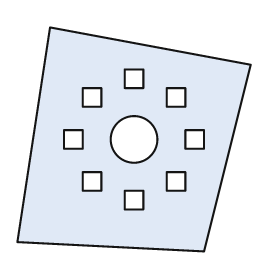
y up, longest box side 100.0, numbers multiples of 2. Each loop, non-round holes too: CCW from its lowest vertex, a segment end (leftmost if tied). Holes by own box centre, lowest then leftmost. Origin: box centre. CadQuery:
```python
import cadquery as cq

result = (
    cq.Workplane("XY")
    .moveTo(30.0, -48.0)
    .lineTo(50.0, 32.0)
    .lineTo(-36.0, 48.0)
    .lineTo(-50.0, -44.0)
    .close()
    .moveTo(-4.0, -30.0)
    .lineTo(4.0, -30.0)
    .lineTo(4.0, -22.0)
    .lineTo(-4.0, -22.0)
    .close()
    .moveTo(-22.0, -22.0)
    .lineTo(-14.0, -22.0)
    .lineTo(-14.0, -14.0)
    .lineTo(-22.0, -14.0)
    .close()
    .moveTo(14.0, -22.0)
    .lineTo(22.0, -22.0)
    .lineTo(22.0, -14.0)
    .lineTo(14.0, -14.0)
    .close()
    .moveTo(-30.0, -4.0)
    .lineTo(-22.0, -4.0)
    .lineTo(-22.0, 4.0)
    .lineTo(-30.0, 4.0)
    .close()
    .moveTo(0.0, 0.0)
    .circle(10.0)
    .moveTo(22.0, -4.0)
    .lineTo(30.0, -4.0)
    .lineTo(30.0, 4.0)
    .lineTo(22.0, 4.0)
    .close()
    .moveTo(-22.0, 14.0)
    .lineTo(-14.0, 14.0)
    .lineTo(-14.0, 22.0)
    .lineTo(-22.0, 22.0)
    .close()
    .moveTo(14.0, 14.0)
    .lineTo(22.0, 14.0)
    .lineTo(22.0, 22.0)
    .lineTo(14.0, 22.0)
    .close()
    .moveTo(-4.0, 22.0)
    .lineTo(4.0, 22.0)
    .lineTo(4.0, 30.0)
    .lineTo(-4.0, 30.0)
    .close()
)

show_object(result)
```